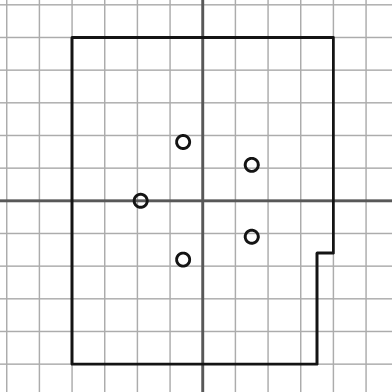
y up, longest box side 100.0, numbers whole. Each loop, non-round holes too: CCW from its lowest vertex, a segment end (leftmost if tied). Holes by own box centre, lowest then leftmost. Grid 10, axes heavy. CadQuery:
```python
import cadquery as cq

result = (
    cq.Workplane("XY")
    .moveTo(-40.0, -50.0)
    .lineTo(35.0, -50.0)
    .lineTo(35.0, -16.0)
    .lineTo(40.0, -16.0)
    .lineTo(40.0, 50.0)
    .lineTo(-40.0, 50.0)
    .close()
    .moveTo(-6.0, -18.0)
    .circle(2.0)
    .moveTo(15.0, -11.0)
    .circle(2.0)
    .moveTo(-19.0, 0.0)
    .circle(2.0)
    .moveTo(15.0, 11.0)
    .circle(2.0)
    .moveTo(-6.0, 18.0)
    .circle(2.0)
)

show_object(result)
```